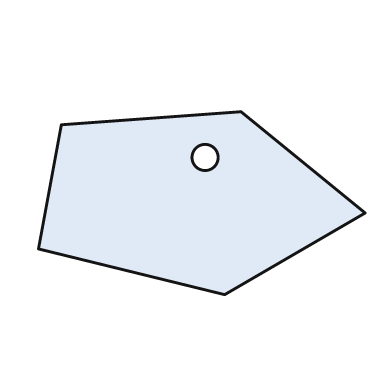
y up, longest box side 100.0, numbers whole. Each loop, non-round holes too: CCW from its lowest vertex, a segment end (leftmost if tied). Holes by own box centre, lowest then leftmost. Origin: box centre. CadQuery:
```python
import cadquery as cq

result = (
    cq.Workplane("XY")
    .moveTo(7.0, -28.0)
    .lineTo(50.0, -3.0)
    .lineTo(12.0, 28.0)
    .lineTo(-43.0, 24.0)
    .lineTo(-50.0, -14.0)
    .close()
    .moveTo(1.0, 14.0)
    .circle(4.0)
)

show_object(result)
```